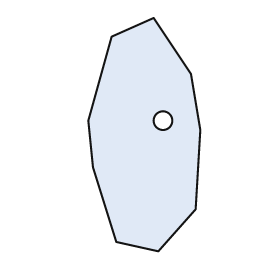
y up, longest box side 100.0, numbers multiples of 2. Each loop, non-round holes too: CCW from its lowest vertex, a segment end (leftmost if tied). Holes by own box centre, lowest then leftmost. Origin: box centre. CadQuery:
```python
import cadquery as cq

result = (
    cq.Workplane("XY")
    .moveTo(6.0, -50.0)
    .lineTo(22.0, -32.0)
    .lineTo(24.0, 2.0)
    .lineTo(20.0, 26.0)
    .lineTo(4.0, 50.0)
    .lineTo(-14.0, 42.0)
    .lineTo(-24.0, 6.0)
    .lineTo(-22.0, -14.0)
    .lineTo(-12.0, -46.0)
    .close()
    .moveTo(8.0, 6.0)
    .circle(4.0)
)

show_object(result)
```